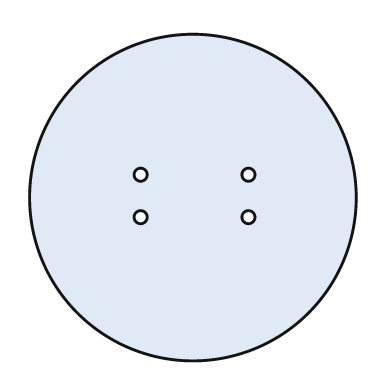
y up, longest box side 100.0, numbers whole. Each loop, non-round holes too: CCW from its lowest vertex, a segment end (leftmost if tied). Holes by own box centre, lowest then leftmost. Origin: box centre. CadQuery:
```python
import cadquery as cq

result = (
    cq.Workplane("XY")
    .moveTo(0.0, 0.0)
    .circle(50.0)
    .moveTo(-16.0, -6.0)
    .circle(2.0)
    .moveTo(17.0, -6.0)
    .circle(2.0)
    .moveTo(-16.0, 7.0)
    .circle(2.0)
    .moveTo(17.0, 7.0)
    .circle(2.0)
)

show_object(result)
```